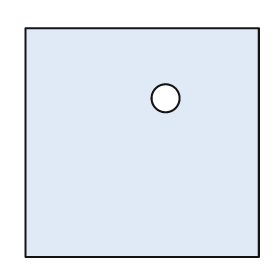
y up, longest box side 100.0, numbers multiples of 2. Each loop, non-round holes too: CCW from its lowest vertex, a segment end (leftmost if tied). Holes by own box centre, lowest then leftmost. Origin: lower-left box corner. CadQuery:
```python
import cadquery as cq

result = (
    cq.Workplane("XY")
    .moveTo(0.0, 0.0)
    .lineTo(100.0, 0.0)
    .lineTo(100.0, 98.0)
    .lineTo(0.0, 98.0)
    .close()
    .moveTo(60.0, 68.0)
    .circle(6.0)
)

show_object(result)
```